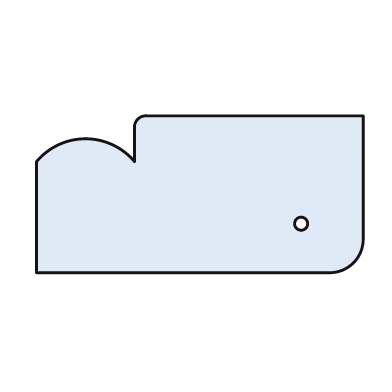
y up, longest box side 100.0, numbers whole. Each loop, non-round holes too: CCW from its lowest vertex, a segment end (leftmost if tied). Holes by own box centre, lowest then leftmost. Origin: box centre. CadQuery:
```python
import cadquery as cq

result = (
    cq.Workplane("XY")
    .moveTo(-50.0, -24.0)
    .lineTo(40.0, -24.0)
    .threePointArc((47.0, -21.0), (50.0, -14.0))
    .lineTo(50.0, 24.0)
    .lineTo(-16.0, 24.0)
    .threePointArc((-19.0, 23.0), (-20.0, 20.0))
    .lineTo(-20.0, 10.0)
    .threePointArc((-35.0, 17.0), (-50.0, 10.0))
    .close()
    .moveTo(31.0, -9.0)
    .circle(2.0)
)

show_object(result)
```